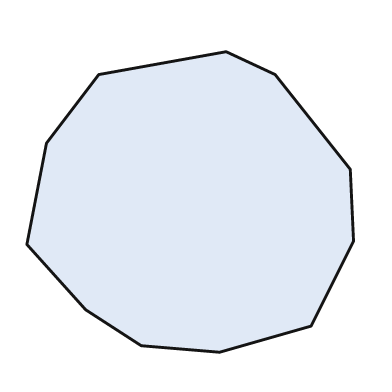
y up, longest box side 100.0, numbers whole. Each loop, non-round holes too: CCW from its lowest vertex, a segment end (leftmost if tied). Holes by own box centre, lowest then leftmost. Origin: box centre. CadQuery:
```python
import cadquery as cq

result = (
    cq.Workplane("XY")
    .moveTo(9.0, -46.0)
    .lineTo(37.0, -38.0)
    .lineTo(50.0, -12.0)
    .lineTo(49.0, 10.0)
    .lineTo(26.0, 39.0)
    .lineTo(11.0, 46.0)
    .lineTo(-28.0, 39.0)
    .lineTo(-44.0, 18.0)
    .lineTo(-50.0, -13.0)
    .lineTo(-32.0, -33.0)
    .lineTo(-15.0, -44.0)
    .close()
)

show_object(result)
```